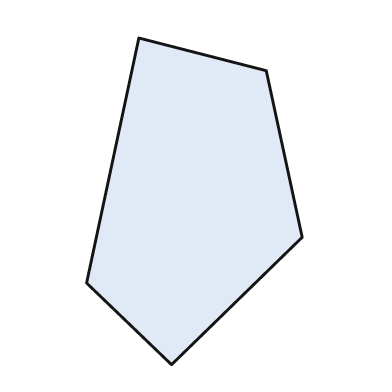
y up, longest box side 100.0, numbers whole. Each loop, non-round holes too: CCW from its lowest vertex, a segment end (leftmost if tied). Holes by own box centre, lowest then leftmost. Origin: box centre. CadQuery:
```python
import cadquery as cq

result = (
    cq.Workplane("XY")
    .moveTo(-7.0, -50.0)
    .lineTo(33.0, -11.0)
    .lineTo(22.0, 40.0)
    .lineTo(-17.0, 50.0)
    .lineTo(-33.0, -25.0)
    .close()
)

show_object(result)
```